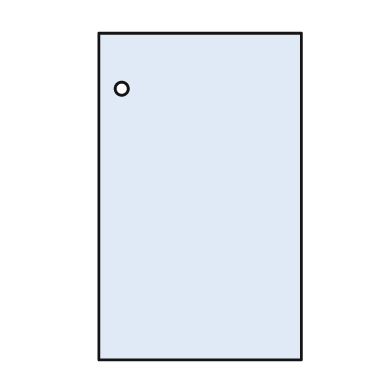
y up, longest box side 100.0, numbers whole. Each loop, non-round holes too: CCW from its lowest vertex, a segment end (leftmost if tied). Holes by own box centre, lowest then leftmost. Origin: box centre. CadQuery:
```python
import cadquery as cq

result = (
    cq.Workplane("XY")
    .moveTo(-31.0, -50.0)
    .lineTo(31.0, -50.0)
    .lineTo(31.0, 50.0)
    .lineTo(-31.0, 50.0)
    .close()
    .moveTo(-24.0, 33.0)
    .circle(2.0)
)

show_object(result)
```